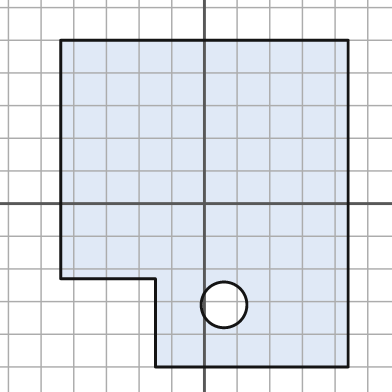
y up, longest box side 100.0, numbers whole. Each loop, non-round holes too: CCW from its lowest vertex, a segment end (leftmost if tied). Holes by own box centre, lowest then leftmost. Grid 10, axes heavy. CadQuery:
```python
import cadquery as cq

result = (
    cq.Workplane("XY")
    .moveTo(-15.0, -50.0)
    .lineTo(44.0, -50.0)
    .lineTo(44.0, 50.0)
    .lineTo(-44.0, 50.0)
    .lineTo(-44.0, -23.0)
    .lineTo(-15.0, -23.0)
    .close()
    .moveTo(6.0, -31.0)
    .circle(7.0)
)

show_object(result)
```